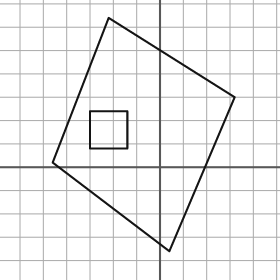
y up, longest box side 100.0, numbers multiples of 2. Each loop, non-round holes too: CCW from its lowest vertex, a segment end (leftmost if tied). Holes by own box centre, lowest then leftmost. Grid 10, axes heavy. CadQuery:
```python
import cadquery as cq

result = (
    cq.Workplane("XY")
    .moveTo(4.0, -36.0)
    .lineTo(32.0, 30.0)
    .lineTo(-22.0, 64.0)
    .lineTo(-46.0, 2.0)
    .close()
    .moveTo(-30.0, 8.0)
    .lineTo(-14.0, 8.0)
    .lineTo(-14.0, 24.0)
    .lineTo(-30.0, 24.0)
    .close()
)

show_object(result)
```